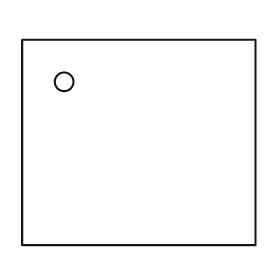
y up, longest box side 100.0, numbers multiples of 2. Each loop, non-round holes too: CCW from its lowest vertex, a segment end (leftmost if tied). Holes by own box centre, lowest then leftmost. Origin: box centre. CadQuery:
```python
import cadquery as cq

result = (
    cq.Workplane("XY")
    .moveTo(-50.0, -44.0)
    .lineTo(50.0, -44.0)
    .lineTo(50.0, 44.0)
    .lineTo(-50.0, 44.0)
    .close()
    .moveTo(-32.0, 26.0)
    .circle(4.0)
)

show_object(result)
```